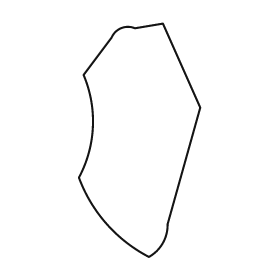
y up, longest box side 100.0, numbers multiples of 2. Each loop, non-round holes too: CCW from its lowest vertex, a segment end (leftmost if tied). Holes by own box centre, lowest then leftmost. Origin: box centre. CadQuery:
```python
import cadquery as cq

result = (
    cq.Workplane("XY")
    .moveTo(4.0, -50.0)
    .threePointArc((10.0, -44.0), (12.0, -36.0))
    .lineTo(26.0, 14.0)
    .lineTo(10.0, 50.0)
    .lineTo(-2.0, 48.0)
    .threePointArc((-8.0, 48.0), (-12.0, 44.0))
    .lineTo(-24.0, 28.0)
    .threePointArc((-20.0, 6.0), (-26.0, -16.0))
    .threePointArc((-14.0, -36.0), (4.0, -50.0))
    .close()
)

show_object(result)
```